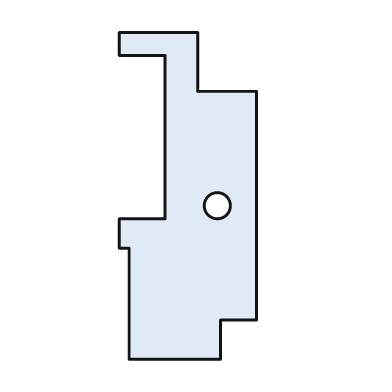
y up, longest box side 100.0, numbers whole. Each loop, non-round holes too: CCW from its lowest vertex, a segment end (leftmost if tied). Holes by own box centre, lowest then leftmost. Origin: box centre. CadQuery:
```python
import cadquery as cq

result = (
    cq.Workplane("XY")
    .moveTo(-18.0, -50.0)
    .lineTo(10.0, -50.0)
    .lineTo(10.0, -38.0)
    .lineTo(21.0, -38.0)
    .lineTo(21.0, 32.0)
    .lineTo(3.0, 32.0)
    .lineTo(3.0, 50.0)
    .lineTo(-21.0, 50.0)
    .lineTo(-21.0, 43.0)
    .lineTo(-7.0, 43.0)
    .lineTo(-7.0, -7.0)
    .lineTo(-21.0, -7.0)
    .lineTo(-21.0, -16.0)
    .lineTo(-18.0, -16.0)
    .close()
    .moveTo(9.0, -3.0)
    .circle(4.0)
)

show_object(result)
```